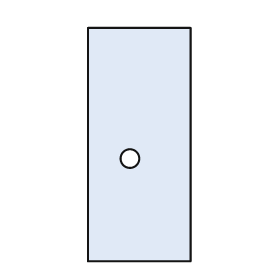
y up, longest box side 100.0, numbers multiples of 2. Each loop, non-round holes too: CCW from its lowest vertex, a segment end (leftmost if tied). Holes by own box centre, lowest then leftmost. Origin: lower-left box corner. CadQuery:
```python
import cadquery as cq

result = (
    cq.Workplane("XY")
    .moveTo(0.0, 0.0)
    .lineTo(44.0, 0.0)
    .lineTo(44.0, 100.0)
    .lineTo(0.0, 100.0)
    .close()
    .moveTo(18.0, 44.0)
    .circle(4.0)
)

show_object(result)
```